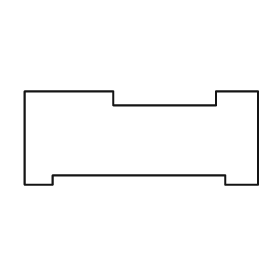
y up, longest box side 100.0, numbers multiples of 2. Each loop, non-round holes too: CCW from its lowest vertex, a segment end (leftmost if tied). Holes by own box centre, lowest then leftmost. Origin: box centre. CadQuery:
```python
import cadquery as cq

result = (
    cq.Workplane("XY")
    .moveTo(-50.0, -20.0)
    .lineTo(-38.0, -20.0)
    .lineTo(-38.0, -16.0)
    .lineTo(36.0, -16.0)
    .lineTo(36.0, -20.0)
    .lineTo(50.0, -20.0)
    .lineTo(50.0, 20.0)
    .lineTo(32.0, 20.0)
    .lineTo(32.0, 14.0)
    .lineTo(-12.0, 14.0)
    .lineTo(-12.0, 20.0)
    .lineTo(-50.0, 20.0)
    .close()
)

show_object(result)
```